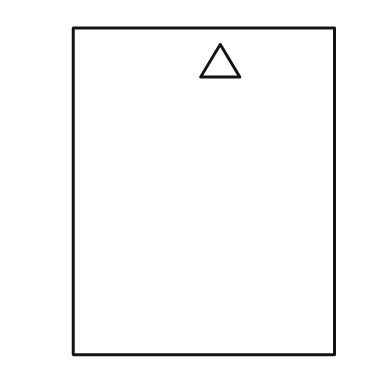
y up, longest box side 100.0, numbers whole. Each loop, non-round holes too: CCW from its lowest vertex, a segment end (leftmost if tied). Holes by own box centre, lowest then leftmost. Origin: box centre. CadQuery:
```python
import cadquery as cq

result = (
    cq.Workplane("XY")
    .moveTo(-40.0, -50.0)
    .lineTo(40.0, -50.0)
    .lineTo(40.0, 50.0)
    .lineTo(-40.0, 50.0)
    .close()
    .moveTo(-1.0, 35.0)
    .lineTo(11.0, 35.0)
    .lineTo(5.0, 45.0)
    .close()
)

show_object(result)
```